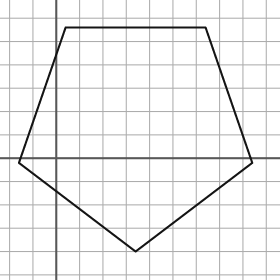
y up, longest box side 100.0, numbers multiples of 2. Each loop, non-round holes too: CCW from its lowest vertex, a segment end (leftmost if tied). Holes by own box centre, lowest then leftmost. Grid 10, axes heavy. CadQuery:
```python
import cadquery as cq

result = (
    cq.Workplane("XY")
    .moveTo(34.0, -40.0)
    .lineTo(84.0, -2.0)
    .lineTo(64.0, 56.0)
    .lineTo(4.0, 56.0)
    .lineTo(-16.0, -2.0)
    .close()
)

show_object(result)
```